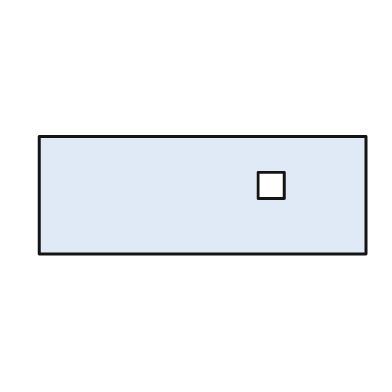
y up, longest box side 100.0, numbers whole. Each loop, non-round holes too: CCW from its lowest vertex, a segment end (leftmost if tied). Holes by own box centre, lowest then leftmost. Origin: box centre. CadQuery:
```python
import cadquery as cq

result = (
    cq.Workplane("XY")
    .moveTo(-50.0, -18.0)
    .lineTo(50.0, -18.0)
    .lineTo(50.0, 18.0)
    .lineTo(-50.0, 18.0)
    .close()
    .moveTo(17.0, -1.0)
    .lineTo(25.0, -1.0)
    .lineTo(25.0, 7.0)
    .lineTo(17.0, 7.0)
    .close()
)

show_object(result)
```